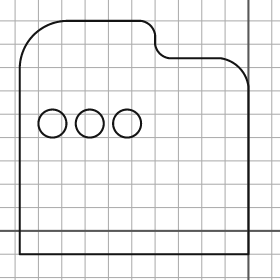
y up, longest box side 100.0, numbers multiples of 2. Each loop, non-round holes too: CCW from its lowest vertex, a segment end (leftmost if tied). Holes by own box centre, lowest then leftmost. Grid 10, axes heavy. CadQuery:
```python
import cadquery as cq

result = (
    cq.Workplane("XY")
    .moveTo(-98.0, -10.0)
    .lineTo(0.0, -10.0)
    .lineTo(0.0, 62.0)
    .threePointArc((-4.0, 70.0), (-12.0, 74.0))
    .lineTo(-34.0, 74.0)
    .threePointArc((-38.0, 76.0), (-40.0, 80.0))
    .lineTo(-40.0, 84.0)
    .threePointArc((-42.0, 88.0), (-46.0, 90.0))
    .lineTo(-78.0, 90.0)
    .threePointArc((-92.0, 84.0), (-98.0, 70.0))
    .close()
    .moveTo(-84.0, 46.0)
    .circle(6.0)
    .moveTo(-68.0, 46.0)
    .circle(6.0)
    .moveTo(-52.0, 46.0)
    .circle(6.0)
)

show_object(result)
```